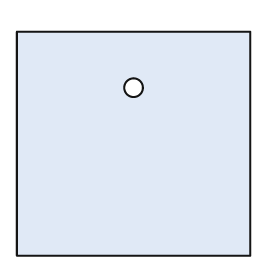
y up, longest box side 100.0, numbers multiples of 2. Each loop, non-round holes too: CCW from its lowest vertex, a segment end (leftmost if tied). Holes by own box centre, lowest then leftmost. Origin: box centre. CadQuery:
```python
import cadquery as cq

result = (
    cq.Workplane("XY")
    .moveTo(-50.0, -48.0)
    .lineTo(50.0, -48.0)
    .lineTo(50.0, 48.0)
    .lineTo(-50.0, 48.0)
    .close()
    .moveTo(0.0, 24.0)
    .circle(4.0)
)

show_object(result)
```